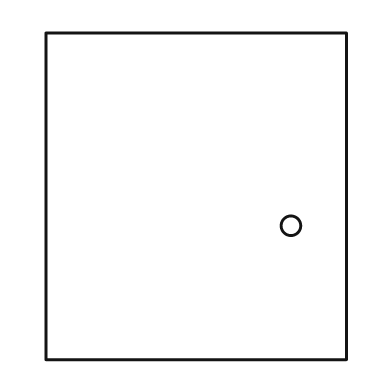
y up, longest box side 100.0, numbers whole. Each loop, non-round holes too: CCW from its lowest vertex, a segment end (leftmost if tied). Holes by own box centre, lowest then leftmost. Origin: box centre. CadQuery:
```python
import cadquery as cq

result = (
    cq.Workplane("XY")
    .moveTo(-46.0, -50.0)
    .lineTo(46.0, -50.0)
    .lineTo(46.0, 50.0)
    .lineTo(-46.0, 50.0)
    .close()
    .moveTo(29.0, -9.0)
    .circle(3.0)
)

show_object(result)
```